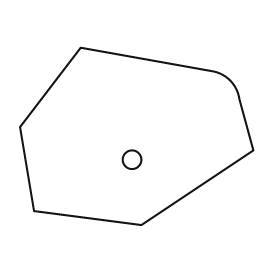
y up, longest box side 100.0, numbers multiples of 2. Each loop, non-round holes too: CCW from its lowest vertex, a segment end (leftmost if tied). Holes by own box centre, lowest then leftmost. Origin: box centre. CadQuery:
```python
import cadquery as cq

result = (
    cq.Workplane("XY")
    .moveTo(2.0, -38.0)
    .lineTo(50.0, -6.0)
    .lineTo(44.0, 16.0)
    .threePointArc((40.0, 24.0), (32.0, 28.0))
    .lineTo(-24.0, 38.0)
    .lineTo(-50.0, 4.0)
    .lineTo(-44.0, -32.0)
    .close()
    .moveTo(-2.0, -10.0)
    .circle(4.0)
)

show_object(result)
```